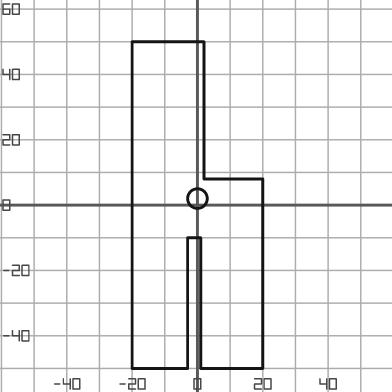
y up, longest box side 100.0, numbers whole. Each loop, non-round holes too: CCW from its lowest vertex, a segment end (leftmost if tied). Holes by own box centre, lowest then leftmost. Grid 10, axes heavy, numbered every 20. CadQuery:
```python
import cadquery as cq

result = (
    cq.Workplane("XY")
    .moveTo(-20.0, -50.0)
    .lineTo(-3.0, -50.0)
    .lineTo(-3.0, -10.0)
    .lineTo(1.0, -10.0)
    .lineTo(1.0, -50.0)
    .lineTo(20.0, -50.0)
    .lineTo(20.0, 8.0)
    .lineTo(2.0, 8.0)
    .lineTo(2.0, 50.0)
    .lineTo(-20.0, 50.0)
    .close()
    .moveTo(0.0, 2.0)
    .circle(3.0)
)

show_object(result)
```